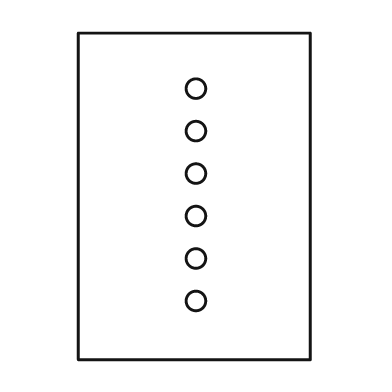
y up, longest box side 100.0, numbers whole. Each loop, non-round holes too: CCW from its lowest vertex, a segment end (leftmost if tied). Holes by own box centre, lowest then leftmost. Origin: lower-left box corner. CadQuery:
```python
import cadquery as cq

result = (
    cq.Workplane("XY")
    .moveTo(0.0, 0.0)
    .lineTo(71.0, 0.0)
    .lineTo(71.0, 100.0)
    .lineTo(0.0, 100.0)
    .close()
    .moveTo(36.0, 18.0)
    .circle(3.0)
    .moveTo(36.0, 31.0)
    .circle(3.0)
    .moveTo(36.0, 44.0)
    .circle(3.0)
    .moveTo(36.0, 57.0)
    .circle(3.0)
    .moveTo(36.0, 70.0)
    .circle(3.0)
    .moveTo(36.0, 83.0)
    .circle(3.0)
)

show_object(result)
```